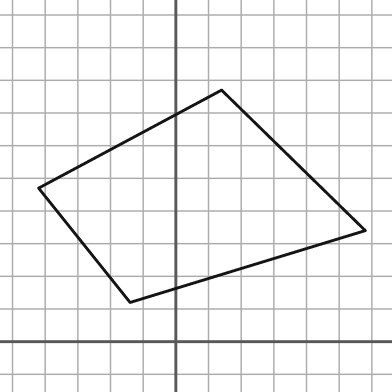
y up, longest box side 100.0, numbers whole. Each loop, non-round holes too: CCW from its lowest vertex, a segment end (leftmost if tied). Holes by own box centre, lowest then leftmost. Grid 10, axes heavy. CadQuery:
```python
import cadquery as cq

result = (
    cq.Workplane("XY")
    .moveTo(-14.0, 12.0)
    .lineTo(58.0, 34.0)
    .lineTo(14.0, 77.0)
    .lineTo(-42.0, 47.0)
    .close()
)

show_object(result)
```